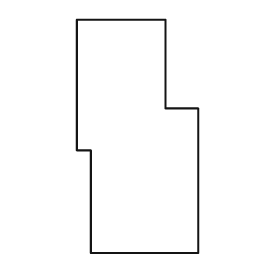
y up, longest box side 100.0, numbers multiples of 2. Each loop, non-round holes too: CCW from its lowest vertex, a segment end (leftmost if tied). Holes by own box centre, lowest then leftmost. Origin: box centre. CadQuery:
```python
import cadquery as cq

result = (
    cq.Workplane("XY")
    .moveTo(-20.0, -50.0)
    .lineTo(26.0, -50.0)
    .lineTo(26.0, 12.0)
    .lineTo(12.0, 12.0)
    .lineTo(12.0, 50.0)
    .lineTo(-26.0, 50.0)
    .lineTo(-26.0, -6.0)
    .lineTo(-20.0, -6.0)
    .close()
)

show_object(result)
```